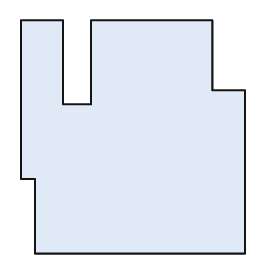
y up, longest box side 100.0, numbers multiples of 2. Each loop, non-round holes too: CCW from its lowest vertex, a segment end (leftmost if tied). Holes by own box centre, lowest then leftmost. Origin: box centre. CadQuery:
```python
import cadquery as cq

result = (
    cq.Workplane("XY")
    .moveTo(-42.0, -50.0)
    .lineTo(48.0, -50.0)
    .lineTo(48.0, 20.0)
    .lineTo(34.0, 20.0)
    .lineTo(34.0, 50.0)
    .lineTo(-18.0, 50.0)
    .lineTo(-18.0, 14.0)
    .lineTo(-30.0, 14.0)
    .lineTo(-30.0, 50.0)
    .lineTo(-48.0, 50.0)
    .lineTo(-48.0, -18.0)
    .lineTo(-42.0, -18.0)
    .close()
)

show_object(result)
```